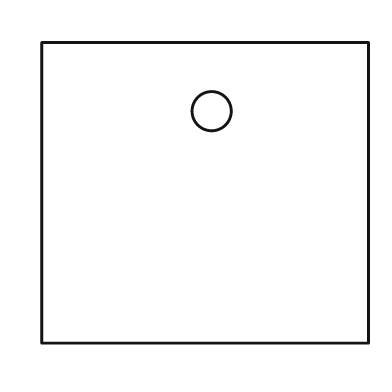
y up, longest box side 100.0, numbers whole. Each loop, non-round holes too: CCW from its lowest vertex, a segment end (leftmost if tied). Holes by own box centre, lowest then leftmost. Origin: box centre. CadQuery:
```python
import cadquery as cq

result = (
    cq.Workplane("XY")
    .moveTo(-50.0, -46.0)
    .lineTo(50.0, -46.0)
    .lineTo(50.0, 46.0)
    .lineTo(-50.0, 46.0)
    .close()
    .moveTo(2.0, 25.0)
    .circle(6.0)
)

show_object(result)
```